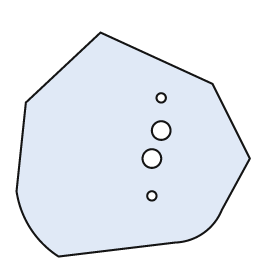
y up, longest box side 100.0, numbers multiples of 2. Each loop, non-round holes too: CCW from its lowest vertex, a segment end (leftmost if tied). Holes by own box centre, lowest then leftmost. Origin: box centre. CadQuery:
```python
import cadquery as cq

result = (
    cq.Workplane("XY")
    .moveTo(-32.0, -48.0)
    .lineTo(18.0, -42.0)
    .threePointArc((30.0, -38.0), (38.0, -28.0))
    .lineTo(50.0, -6.0)
    .lineTo(34.0, 26.0)
    .lineTo(-14.0, 48.0)
    .lineTo(-46.0, 18.0)
    .lineTo(-50.0, -20.0)
    .threePointArc((-44.0, -36.0), (-32.0, -48.0))
    .close()
    .moveTo(8.0, -22.0)
    .circle(2.0)
    .moveTo(8.0, -6.0)
    .circle(4.0)
    .moveTo(12.0, 6.0)
    .circle(4.0)
    .moveTo(12.0, 20.0)
    .circle(2.0)
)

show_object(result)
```